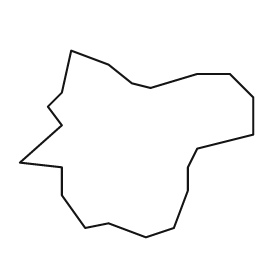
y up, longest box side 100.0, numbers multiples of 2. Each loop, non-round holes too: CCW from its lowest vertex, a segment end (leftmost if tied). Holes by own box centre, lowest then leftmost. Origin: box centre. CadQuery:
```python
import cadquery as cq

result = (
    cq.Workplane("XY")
    .moveTo(4.0, -40.0)
    .lineTo(16.0, -36.0)
    .lineTo(22.0, -20.0)
    .lineTo(22.0, -10.0)
    .lineTo(26.0, -2.0)
    .lineTo(50.0, 4.0)
    .lineTo(50.0, 20.0)
    .lineTo(40.0, 30.0)
    .lineTo(26.0, 30.0)
    .lineTo(6.0, 24.0)
    .lineTo(-2.0, 26.0)
    .lineTo(-12.0, 34.0)
    .lineTo(-28.0, 40.0)
    .lineTo(-32.0, 22.0)
    .lineTo(-38.0, 16.0)
    .lineTo(-32.0, 8.0)
    .lineTo(-50.0, -8.0)
    .lineTo(-32.0, -10.0)
    .lineTo(-32.0, -22.0)
    .lineTo(-22.0, -36.0)
    .lineTo(-12.0, -34.0)
    .close()
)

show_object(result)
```